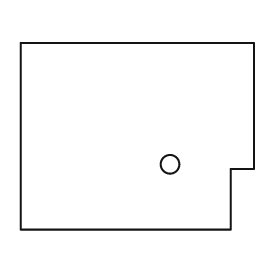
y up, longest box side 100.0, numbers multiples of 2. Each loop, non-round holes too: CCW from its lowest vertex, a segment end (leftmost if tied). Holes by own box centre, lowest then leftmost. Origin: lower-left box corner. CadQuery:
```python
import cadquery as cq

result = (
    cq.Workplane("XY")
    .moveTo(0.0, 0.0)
    .lineTo(90.0, 0.0)
    .lineTo(90.0, 26.0)
    .lineTo(100.0, 26.0)
    .lineTo(100.0, 80.0)
    .lineTo(0.0, 80.0)
    .close()
    .moveTo(64.0, 28.0)
    .circle(4.0)
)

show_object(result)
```